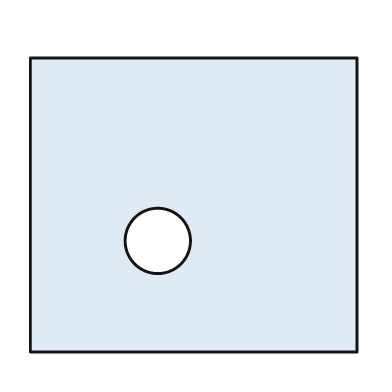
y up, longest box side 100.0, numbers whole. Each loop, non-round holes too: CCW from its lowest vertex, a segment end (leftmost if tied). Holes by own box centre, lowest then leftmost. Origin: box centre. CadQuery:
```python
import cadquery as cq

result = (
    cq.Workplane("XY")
    .moveTo(-50.0, -45.0)
    .lineTo(50.0, -45.0)
    .lineTo(50.0, 45.0)
    .lineTo(-50.0, 45.0)
    .close()
    .moveTo(-11.0, -11.0)
    .circle(10.0)
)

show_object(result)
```